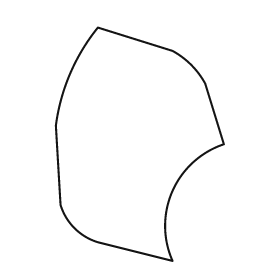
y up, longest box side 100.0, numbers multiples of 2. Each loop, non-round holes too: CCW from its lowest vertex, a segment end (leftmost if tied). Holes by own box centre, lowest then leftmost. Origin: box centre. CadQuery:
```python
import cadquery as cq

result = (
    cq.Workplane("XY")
    .moveTo(14.0, -50.0)
    .threePointArc((14.0, -20.0), (36.0, 0.0))
    .lineTo(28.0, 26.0)
    .threePointArc((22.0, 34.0), (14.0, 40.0))
    .lineTo(-18.0, 50.0)
    .threePointArc((-30.0, 30.0), (-36.0, 8.0))
    .lineTo(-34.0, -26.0)
    .threePointArc((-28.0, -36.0), (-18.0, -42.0))
    .close()
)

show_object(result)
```